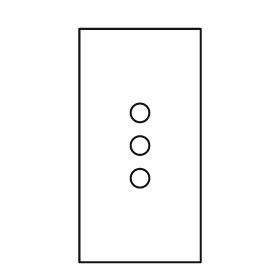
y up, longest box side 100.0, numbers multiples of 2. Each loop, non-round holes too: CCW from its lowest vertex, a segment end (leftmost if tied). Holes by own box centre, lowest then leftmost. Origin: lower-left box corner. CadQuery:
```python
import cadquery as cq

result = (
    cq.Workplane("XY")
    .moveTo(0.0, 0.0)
    .lineTo(52.0, 0.0)
    .lineTo(52.0, 100.0)
    .lineTo(0.0, 100.0)
    .close()
    .moveTo(26.0, 36.0)
    .circle(4.0)
    .moveTo(26.0, 50.0)
    .circle(4.0)
    .moveTo(26.0, 64.0)
    .circle(4.0)
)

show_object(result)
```